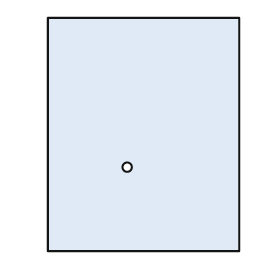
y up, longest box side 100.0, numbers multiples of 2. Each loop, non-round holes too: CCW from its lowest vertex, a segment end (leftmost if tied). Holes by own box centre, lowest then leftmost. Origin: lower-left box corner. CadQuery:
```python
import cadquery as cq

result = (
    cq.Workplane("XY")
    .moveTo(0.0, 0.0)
    .lineTo(82.0, 0.0)
    .lineTo(82.0, 100.0)
    .lineTo(0.0, 100.0)
    .close()
    .moveTo(34.0, 36.0)
    .circle(2.0)
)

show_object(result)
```